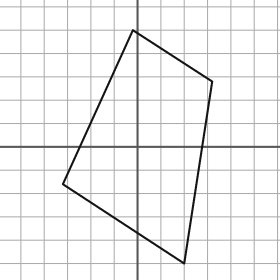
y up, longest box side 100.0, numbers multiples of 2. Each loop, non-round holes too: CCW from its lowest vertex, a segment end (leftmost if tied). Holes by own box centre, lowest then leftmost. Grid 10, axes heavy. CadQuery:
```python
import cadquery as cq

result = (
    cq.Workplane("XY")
    .moveTo(20.0, -50.0)
    .lineTo(32.0, 28.0)
    .lineTo(-2.0, 50.0)
    .lineTo(-32.0, -16.0)
    .close()
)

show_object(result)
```